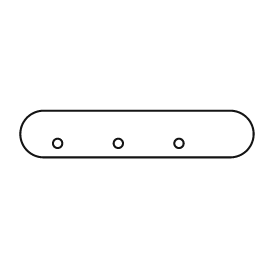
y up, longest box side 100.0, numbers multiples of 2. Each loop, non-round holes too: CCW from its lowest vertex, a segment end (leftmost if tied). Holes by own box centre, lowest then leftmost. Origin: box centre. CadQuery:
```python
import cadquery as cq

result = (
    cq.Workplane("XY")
    .moveTo(-40.0, -10.0)
    .lineTo(40.0, -10.0)
    .threePointArc((50.0, 0.0), (40.0, 10.0))
    .lineTo(-40.0, 10.0)
    .threePointArc((-50.0, 0.0), (-40.0, -10.0))
    .close()
    .moveTo(-34.0, -4.0)
    .circle(2.0)
    .moveTo(-8.0, -4.0)
    .circle(2.0)
    .moveTo(18.0, -4.0)
    .circle(2.0)
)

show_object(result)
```